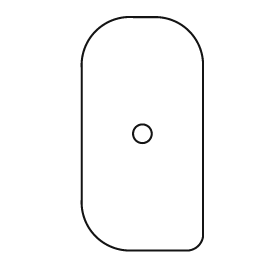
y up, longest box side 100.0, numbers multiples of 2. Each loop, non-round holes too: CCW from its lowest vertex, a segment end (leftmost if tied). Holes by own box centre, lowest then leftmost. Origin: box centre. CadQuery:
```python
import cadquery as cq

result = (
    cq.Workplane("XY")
    .moveTo(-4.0, -50.0)
    .lineTo(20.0, -50.0)
    .threePointArc((24.0, -48.0), (26.0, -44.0))
    .lineTo(26.0, 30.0)
    .threePointArc((20.0, 44.0), (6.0, 50.0))
    .lineTo(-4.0, 50.0)
    .threePointArc((-20.0, 44.0), (-26.0, 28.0))
    .lineTo(-26.0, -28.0)
    .threePointArc((-20.0, -44.0), (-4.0, -50.0))
    .close()
    .moveTo(0.0, 0.0)
    .circle(4.0)
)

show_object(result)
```